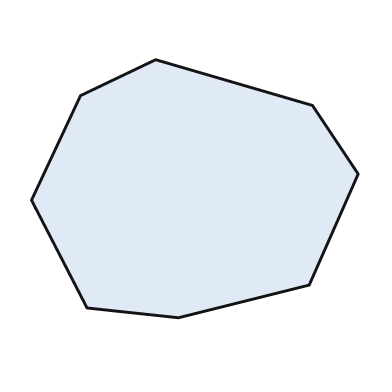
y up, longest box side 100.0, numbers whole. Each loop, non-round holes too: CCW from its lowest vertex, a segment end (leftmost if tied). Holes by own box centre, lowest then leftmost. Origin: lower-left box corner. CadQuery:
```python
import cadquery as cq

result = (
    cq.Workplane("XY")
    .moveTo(45.0, 0.0)
    .lineTo(85.0, 10.0)
    .lineTo(100.0, 44.0)
    .lineTo(86.0, 65.0)
    .lineTo(38.0, 79.0)
    .lineTo(15.0, 68.0)
    .lineTo(0.0, 36.0)
    .lineTo(17.0, 3.0)
    .close()
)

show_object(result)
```